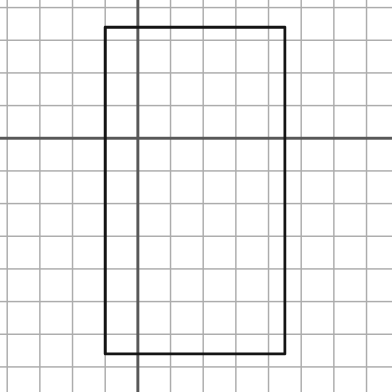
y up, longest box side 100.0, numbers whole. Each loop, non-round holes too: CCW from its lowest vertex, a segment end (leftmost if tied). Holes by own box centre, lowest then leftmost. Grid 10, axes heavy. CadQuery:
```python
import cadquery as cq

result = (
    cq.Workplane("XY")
    .moveTo(-10.0, -66.0)
    .lineTo(45.0, -66.0)
    .lineTo(45.0, 34.0)
    .lineTo(-10.0, 34.0)
    .close()
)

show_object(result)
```